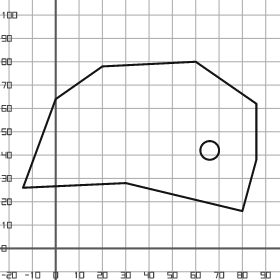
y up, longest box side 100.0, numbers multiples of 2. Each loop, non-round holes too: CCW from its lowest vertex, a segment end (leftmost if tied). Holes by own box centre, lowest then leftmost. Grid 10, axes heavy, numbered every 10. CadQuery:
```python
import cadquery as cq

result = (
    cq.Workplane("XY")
    .moveTo(80.0, 16.0)
    .lineTo(86.0, 38.0)
    .lineTo(86.0, 62.0)
    .lineTo(60.0, 80.0)
    .lineTo(20.0, 78.0)
    .lineTo(0.0, 64.0)
    .lineTo(-14.0, 26.0)
    .lineTo(30.0, 28.0)
    .close()
    .moveTo(66.0, 42.0)
    .circle(4.0)
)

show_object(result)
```